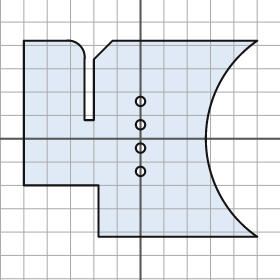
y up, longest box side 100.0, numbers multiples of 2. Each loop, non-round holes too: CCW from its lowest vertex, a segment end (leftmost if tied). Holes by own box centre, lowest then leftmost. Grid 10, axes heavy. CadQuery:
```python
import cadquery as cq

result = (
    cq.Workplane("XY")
    .moveTo(-18.0, -42.0)
    .lineTo(50.0, -42.0)
    .threePointArc((28.0, 0.0), (50.0, 42.0))
    .lineTo(-12.0, 42.0)
    .lineTo(-20.0, 34.0)
    .lineTo(-20.0, 8.0)
    .lineTo(-24.0, 8.0)
    .lineTo(-24.0, 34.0)
    .threePointArc((-26.0, 40.0), (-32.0, 42.0))
    .lineTo(-50.0, 42.0)
    .lineTo(-50.0, -20.0)
    .lineTo(-18.0, -20.0)
    .close()
    .moveTo(0.0, -14.0)
    .circle(2.0)
    .moveTo(0.0, -4.0)
    .circle(2.0)
    .moveTo(0.0, 6.0)
    .circle(2.0)
    .moveTo(0.0, 16.0)
    .circle(2.0)
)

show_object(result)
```